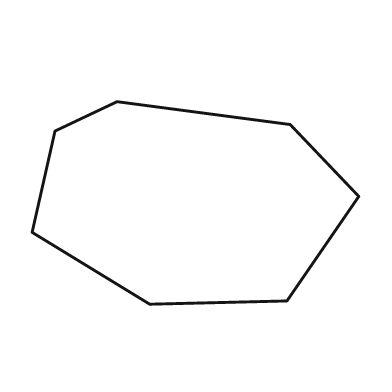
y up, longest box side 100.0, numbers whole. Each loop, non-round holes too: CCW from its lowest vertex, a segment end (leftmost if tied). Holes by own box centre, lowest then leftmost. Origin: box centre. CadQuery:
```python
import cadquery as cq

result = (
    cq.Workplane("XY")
    .moveTo(-14.0, -31.0)
    .lineTo(28.0, -30.0)
    .lineTo(50.0, 2.0)
    .lineTo(29.0, 24.0)
    .lineTo(-24.0, 31.0)
    .lineTo(-43.0, 22.0)
    .lineTo(-50.0, -9.0)
    .close()
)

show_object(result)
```